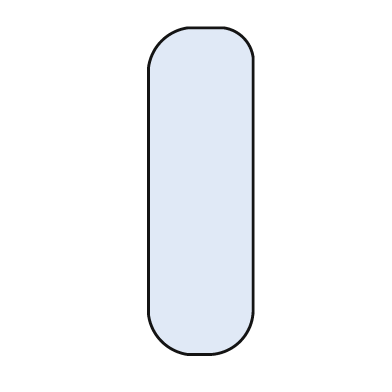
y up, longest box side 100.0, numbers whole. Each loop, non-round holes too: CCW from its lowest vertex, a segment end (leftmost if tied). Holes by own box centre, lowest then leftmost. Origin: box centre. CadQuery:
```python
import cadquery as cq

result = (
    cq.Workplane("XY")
    .moveTo(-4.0, -50.0)
    .lineTo(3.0, -50.0)
    .threePointArc((12.0, -46.0), (16.0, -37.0))
    .lineTo(16.0, 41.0)
    .threePointArc((13.0, 47.0), (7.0, 50.0))
    .lineTo(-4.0, 50.0)
    .threePointArc((-12.0, 46.0), (-16.0, 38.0))
    .lineTo(-16.0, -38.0)
    .threePointArc((-12.0, -46.0), (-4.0, -50.0))
    .close()
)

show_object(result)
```